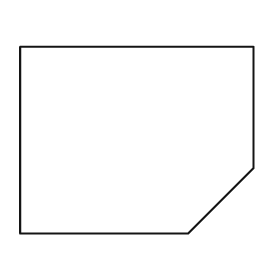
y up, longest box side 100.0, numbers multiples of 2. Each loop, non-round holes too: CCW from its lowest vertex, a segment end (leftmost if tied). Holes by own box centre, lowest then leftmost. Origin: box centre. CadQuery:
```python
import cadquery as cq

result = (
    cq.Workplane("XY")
    .moveTo(-50.0, -40.0)
    .lineTo(22.0, -40.0)
    .lineTo(50.0, -12.0)
    .lineTo(50.0, 40.0)
    .lineTo(-50.0, 40.0)
    .close()
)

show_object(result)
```